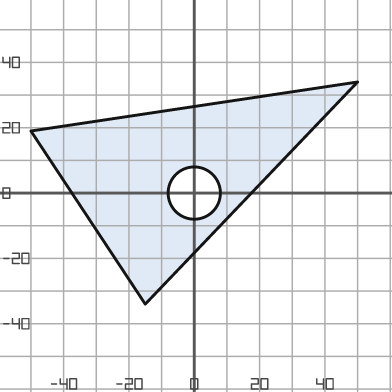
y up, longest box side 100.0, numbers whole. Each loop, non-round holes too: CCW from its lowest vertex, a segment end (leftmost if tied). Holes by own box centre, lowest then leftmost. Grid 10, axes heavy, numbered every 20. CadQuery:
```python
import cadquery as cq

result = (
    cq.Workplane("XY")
    .moveTo(-15.0, -34.0)
    .lineTo(50.0, 34.0)
    .lineTo(-50.0, 19.0)
    .close()
    .moveTo(0.0, 0.0)
    .circle(8.0)
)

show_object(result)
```